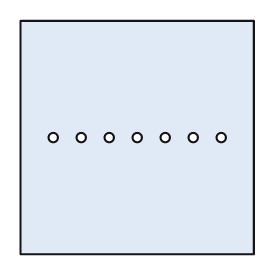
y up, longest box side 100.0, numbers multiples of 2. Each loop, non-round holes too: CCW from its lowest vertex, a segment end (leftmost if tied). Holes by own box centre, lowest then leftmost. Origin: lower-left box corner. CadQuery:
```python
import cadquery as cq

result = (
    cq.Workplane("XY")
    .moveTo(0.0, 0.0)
    .lineTo(100.0, 0.0)
    .lineTo(100.0, 100.0)
    .lineTo(0.0, 100.0)
    .close()
    .moveTo(14.0, 50.0)
    .circle(2.0)
    .moveTo(26.0, 50.0)
    .circle(2.0)
    .moveTo(38.0, 50.0)
    .circle(2.0)
    .moveTo(50.0, 50.0)
    .circle(2.0)
    .moveTo(62.0, 50.0)
    .circle(2.0)
    .moveTo(74.0, 50.0)
    .circle(2.0)
    .moveTo(86.0, 50.0)
    .circle(2.0)
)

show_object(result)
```